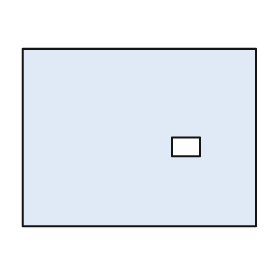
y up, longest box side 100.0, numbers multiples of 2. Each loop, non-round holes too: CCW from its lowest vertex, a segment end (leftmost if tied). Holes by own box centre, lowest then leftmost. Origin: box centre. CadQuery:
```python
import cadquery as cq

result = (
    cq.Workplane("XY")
    .moveTo(-50.0, -38.0)
    .lineTo(50.0, -38.0)
    .lineTo(50.0, 38.0)
    .lineTo(-50.0, 38.0)
    .close()
    .moveTo(14.0, -8.0)
    .lineTo(26.0, -8.0)
    .lineTo(26.0, 0.0)
    .lineTo(14.0, 0.0)
    .close()
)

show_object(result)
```